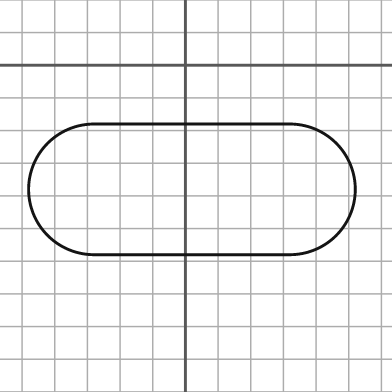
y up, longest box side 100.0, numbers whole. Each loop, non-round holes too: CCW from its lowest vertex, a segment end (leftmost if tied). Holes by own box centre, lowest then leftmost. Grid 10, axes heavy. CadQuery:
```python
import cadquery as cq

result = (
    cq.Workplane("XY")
    .moveTo(-28.0, -58.0)
    .lineTo(32.0, -58.0)
    .threePointArc((52.0, -38.0), (32.0, -18.0))
    .lineTo(-28.0, -18.0)
    .threePointArc((-48.0, -38.0), (-28.0, -58.0))
    .close()
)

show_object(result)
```